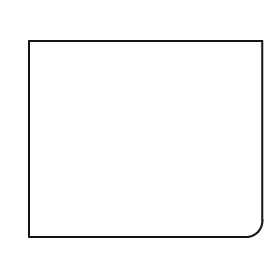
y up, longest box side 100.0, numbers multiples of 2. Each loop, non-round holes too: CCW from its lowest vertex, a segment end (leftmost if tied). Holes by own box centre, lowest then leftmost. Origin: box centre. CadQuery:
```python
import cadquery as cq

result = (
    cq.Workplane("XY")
    .moveTo(-50.0, -42.0)
    .lineTo(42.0, -42.0)
    .threePointArc((48.0, -40.0), (50.0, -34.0))
    .lineTo(50.0, 42.0)
    .lineTo(-50.0, 42.0)
    .close()
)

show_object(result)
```